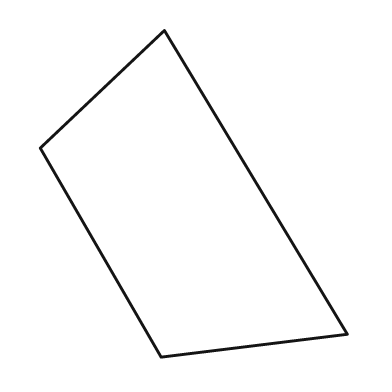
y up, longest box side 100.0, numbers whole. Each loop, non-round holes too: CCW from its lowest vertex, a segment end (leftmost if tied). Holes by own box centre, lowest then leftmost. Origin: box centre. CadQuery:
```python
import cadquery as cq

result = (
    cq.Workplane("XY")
    .moveTo(-10.0, -50.0)
    .lineTo(47.0, -43.0)
    .lineTo(-9.0, 50.0)
    .lineTo(-47.0, 14.0)
    .close()
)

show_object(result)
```